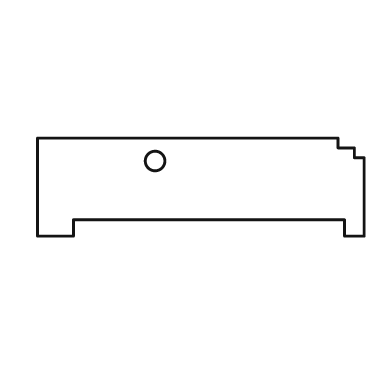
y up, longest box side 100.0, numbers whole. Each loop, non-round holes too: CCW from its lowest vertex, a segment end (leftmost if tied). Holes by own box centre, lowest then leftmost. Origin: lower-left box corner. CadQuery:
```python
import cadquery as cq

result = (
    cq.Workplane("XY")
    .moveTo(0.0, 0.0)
    .lineTo(11.0, 0.0)
    .lineTo(11.0, 5.0)
    .lineTo(94.0, 5.0)
    .lineTo(94.0, 0.0)
    .lineTo(100.0, 0.0)
    .lineTo(100.0, 24.0)
    .lineTo(97.0, 24.0)
    .lineTo(97.0, 27.0)
    .lineTo(92.0, 27.0)
    .lineTo(92.0, 30.0)
    .lineTo(0.0, 30.0)
    .close()
    .moveTo(36.0, 23.0)
    .circle(3.0)
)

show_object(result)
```